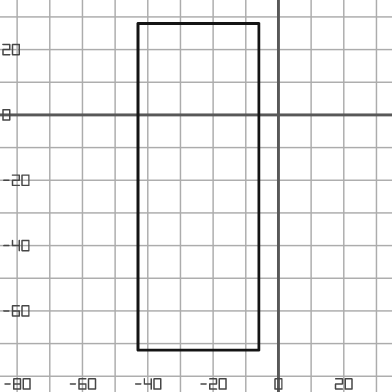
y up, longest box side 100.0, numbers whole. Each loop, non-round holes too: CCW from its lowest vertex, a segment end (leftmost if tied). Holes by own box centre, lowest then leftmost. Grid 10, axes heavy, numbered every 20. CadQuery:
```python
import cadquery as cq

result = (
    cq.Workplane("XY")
    .moveTo(-43.0, -72.0)
    .lineTo(-6.0, -72.0)
    .lineTo(-6.0, 28.0)
    .lineTo(-43.0, 28.0)
    .close()
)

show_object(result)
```